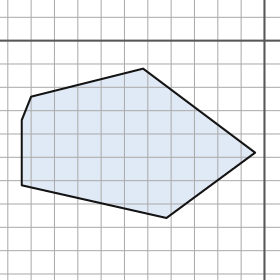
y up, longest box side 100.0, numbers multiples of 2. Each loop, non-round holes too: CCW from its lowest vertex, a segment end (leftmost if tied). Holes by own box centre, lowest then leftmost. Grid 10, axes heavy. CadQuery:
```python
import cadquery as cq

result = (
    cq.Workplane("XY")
    .moveTo(-42.0, -76.0)
    .lineTo(-4.0, -48.0)
    .lineTo(-52.0, -12.0)
    .lineTo(-100.0, -24.0)
    .lineTo(-104.0, -34.0)
    .lineTo(-104.0, -62.0)
    .close()
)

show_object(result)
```